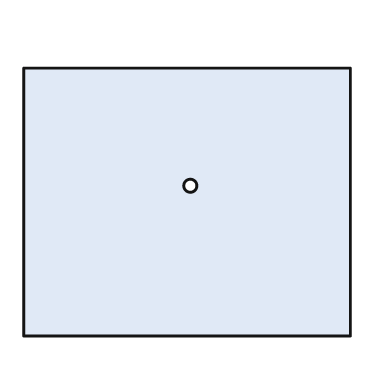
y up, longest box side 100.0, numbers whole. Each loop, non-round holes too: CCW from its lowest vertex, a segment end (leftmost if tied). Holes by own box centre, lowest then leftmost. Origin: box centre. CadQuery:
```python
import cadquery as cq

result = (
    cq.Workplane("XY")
    .moveTo(-50.0, -41.0)
    .lineTo(50.0, -41.0)
    .lineTo(50.0, 41.0)
    .lineTo(-50.0, 41.0)
    .close()
    .moveTo(1.0, 5.0)
    .circle(2.0)
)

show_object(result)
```